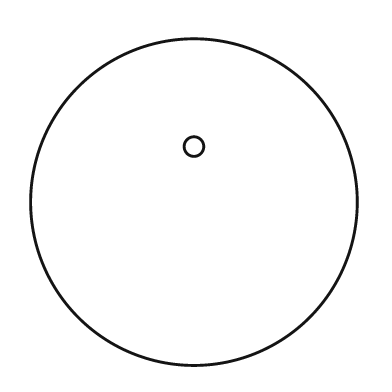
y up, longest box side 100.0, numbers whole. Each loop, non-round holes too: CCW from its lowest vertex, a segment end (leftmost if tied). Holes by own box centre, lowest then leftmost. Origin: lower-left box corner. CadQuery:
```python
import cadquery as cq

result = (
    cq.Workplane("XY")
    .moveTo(50.0, 50.0)
    .circle(50.0)
    .moveTo(50.0, 67.0)
    .circle(3.0)
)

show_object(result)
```